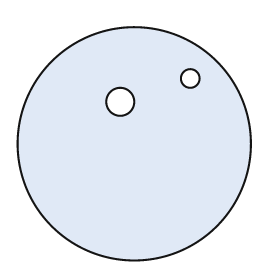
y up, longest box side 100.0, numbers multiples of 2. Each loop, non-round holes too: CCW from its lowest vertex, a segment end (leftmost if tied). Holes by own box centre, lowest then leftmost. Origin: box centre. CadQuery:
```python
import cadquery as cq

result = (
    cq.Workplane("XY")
    .moveTo(0.0, 0.0)
    .circle(50.0)
    .moveTo(-6.0, 18.0)
    .circle(6.0)
    .moveTo(24.0, 28.0)
    .circle(4.0)
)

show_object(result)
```